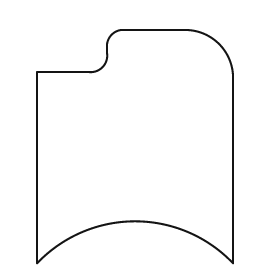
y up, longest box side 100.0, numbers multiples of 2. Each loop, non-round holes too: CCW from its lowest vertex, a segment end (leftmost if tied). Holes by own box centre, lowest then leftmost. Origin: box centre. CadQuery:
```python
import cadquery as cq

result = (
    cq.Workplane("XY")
    .moveTo(-42.0, -50.0)
    .threePointArc((0.0, -32.0), (42.0, -50.0))
    .lineTo(42.0, 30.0)
    .threePointArc((36.0, 44.0), (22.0, 50.0))
    .lineTo(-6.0, 50.0)
    .threePointArc((-10.0, 48.0), (-12.0, 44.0))
    .lineTo(-12.0, 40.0)
    .threePointArc((-14.0, 34.0), (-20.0, 32.0))
    .lineTo(-42.0, 32.0)
    .close()
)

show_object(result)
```